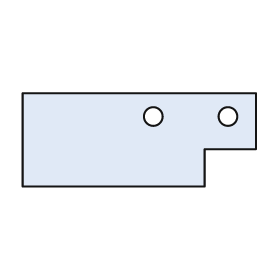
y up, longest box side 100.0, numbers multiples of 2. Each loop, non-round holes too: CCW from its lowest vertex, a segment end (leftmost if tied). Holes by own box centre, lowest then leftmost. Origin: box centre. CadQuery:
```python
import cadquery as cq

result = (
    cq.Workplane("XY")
    .moveTo(-50.0, -20.0)
    .lineTo(28.0, -20.0)
    .lineTo(28.0, -4.0)
    .lineTo(50.0, -4.0)
    .lineTo(50.0, 20.0)
    .lineTo(-50.0, 20.0)
    .close()
    .moveTo(6.0, 10.0)
    .circle(4.0)
    .moveTo(38.0, 10.0)
    .circle(4.0)
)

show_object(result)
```